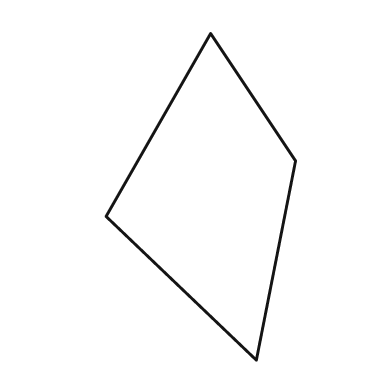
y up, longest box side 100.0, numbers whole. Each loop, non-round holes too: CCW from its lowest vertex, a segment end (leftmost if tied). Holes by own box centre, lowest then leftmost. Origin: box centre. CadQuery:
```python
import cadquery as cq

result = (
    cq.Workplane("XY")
    .moveTo(17.0, -50.0)
    .lineTo(29.0, 11.0)
    .lineTo(3.0, 50.0)
    .lineTo(-29.0, -6.0)
    .close()
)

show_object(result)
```